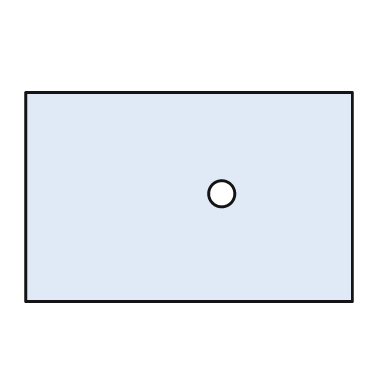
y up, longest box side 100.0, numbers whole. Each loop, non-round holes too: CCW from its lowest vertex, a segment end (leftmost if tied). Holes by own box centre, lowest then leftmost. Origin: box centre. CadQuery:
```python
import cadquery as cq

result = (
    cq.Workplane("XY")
    .moveTo(-50.0, -32.0)
    .lineTo(50.0, -32.0)
    .lineTo(50.0, 32.0)
    .lineTo(-50.0, 32.0)
    .close()
    .moveTo(10.0, 1.0)
    .circle(4.0)
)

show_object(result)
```